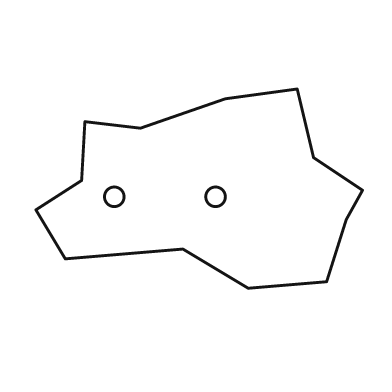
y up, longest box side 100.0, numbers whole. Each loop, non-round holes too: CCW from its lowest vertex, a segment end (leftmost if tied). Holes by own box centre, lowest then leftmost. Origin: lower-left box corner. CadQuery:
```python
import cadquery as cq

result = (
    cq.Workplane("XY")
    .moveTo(65.0, 0.0)
    .lineTo(89.0, 2.0)
    .lineTo(95.0, 21.0)
    .lineTo(100.0, 30.0)
    .lineTo(85.0, 40.0)
    .lineTo(80.0, 61.0)
    .lineTo(58.0, 58.0)
    .lineTo(32.0, 49.0)
    .lineTo(15.0, 51.0)
    .lineTo(14.0, 33.0)
    .lineTo(0.0, 24.0)
    .lineTo(9.0, 9.0)
    .lineTo(45.0, 12.0)
    .close()
    .moveTo(24.0, 28.0)
    .circle(3.0)
    .moveTo(55.0, 28.0)
    .circle(3.0)
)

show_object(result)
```